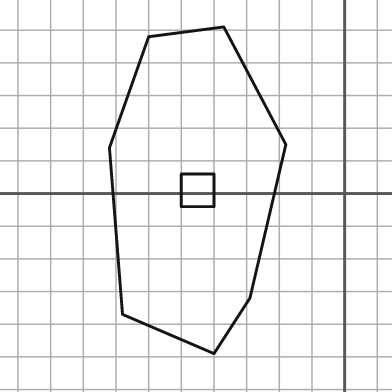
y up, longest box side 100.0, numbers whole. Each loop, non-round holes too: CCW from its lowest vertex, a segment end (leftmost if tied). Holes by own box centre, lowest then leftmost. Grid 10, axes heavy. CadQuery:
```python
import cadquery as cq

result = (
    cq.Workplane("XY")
    .moveTo(-40.0, -49.0)
    .lineTo(-29.0, -32.0)
    .lineTo(-18.0, 15.0)
    .lineTo(-37.0, 51.0)
    .lineTo(-60.0, 48.0)
    .lineTo(-72.0, 14.0)
    .lineTo(-68.0, -37.0)
    .close()
    .moveTo(-50.0, -4.0)
    .lineTo(-40.0, -4.0)
    .lineTo(-40.0, 6.0)
    .lineTo(-50.0, 6.0)
    .close()
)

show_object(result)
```